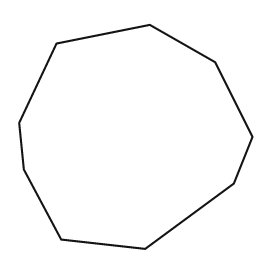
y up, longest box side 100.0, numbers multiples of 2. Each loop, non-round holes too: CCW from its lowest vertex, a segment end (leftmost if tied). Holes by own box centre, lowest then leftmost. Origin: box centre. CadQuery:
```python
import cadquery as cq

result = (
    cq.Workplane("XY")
    .moveTo(4.0, -48.0)
    .lineTo(42.0, -20.0)
    .lineTo(50.0, 0.0)
    .lineTo(34.0, 32.0)
    .lineTo(6.0, 48.0)
    .lineTo(-34.0, 40.0)
    .lineTo(-50.0, 6.0)
    .lineTo(-48.0, -14.0)
    .lineTo(-32.0, -44.0)
    .close()
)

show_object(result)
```